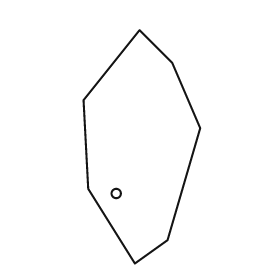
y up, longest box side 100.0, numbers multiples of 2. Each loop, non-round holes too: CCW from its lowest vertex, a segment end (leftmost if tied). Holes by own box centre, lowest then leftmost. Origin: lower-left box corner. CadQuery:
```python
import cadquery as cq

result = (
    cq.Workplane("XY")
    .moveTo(22.0, 0.0)
    .lineTo(36.0, 10.0)
    .lineTo(50.0, 58.0)
    .lineTo(38.0, 86.0)
    .lineTo(24.0, 100.0)
    .lineTo(0.0, 70.0)
    .lineTo(2.0, 32.0)
    .close()
    .moveTo(14.0, 30.0)
    .circle(2.0)
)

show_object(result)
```